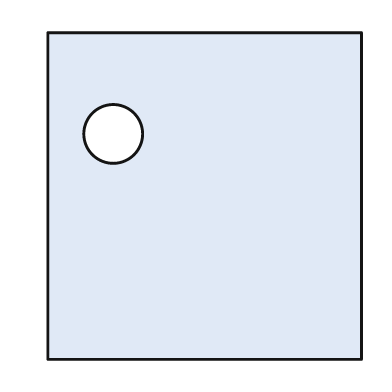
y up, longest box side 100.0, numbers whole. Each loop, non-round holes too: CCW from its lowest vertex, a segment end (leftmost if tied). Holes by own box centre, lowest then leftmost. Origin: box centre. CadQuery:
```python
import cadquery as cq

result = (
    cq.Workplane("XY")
    .moveTo(-48.0, -50.0)
    .lineTo(48.0, -50.0)
    .lineTo(48.0, 50.0)
    .lineTo(-48.0, 50.0)
    .close()
    .moveTo(-28.0, 19.0)
    .circle(9.0)
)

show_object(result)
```